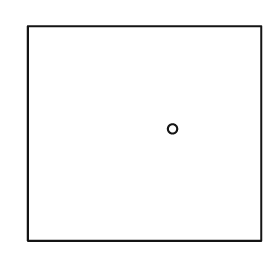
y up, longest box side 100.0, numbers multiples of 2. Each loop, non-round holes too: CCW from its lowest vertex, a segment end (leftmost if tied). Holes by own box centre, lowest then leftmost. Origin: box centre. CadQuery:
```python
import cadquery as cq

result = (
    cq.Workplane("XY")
    .moveTo(-50.0, -46.0)
    .lineTo(50.0, -46.0)
    .lineTo(50.0, 46.0)
    .lineTo(-50.0, 46.0)
    .close()
    .moveTo(12.0, 2.0)
    .circle(2.0)
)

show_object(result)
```